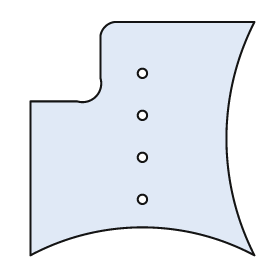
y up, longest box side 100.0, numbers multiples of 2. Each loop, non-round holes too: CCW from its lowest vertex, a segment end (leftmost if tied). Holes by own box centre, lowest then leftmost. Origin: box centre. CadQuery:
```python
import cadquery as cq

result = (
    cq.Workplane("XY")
    .moveTo(-48.0, -50.0)
    .threePointArc((0.0, -38.0), (48.0, -50.0))
    .threePointArc((36.0, 0.0), (48.0, 50.0))
    .lineTo(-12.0, 50.0)
    .threePointArc((-16.0, 48.0), (-18.0, 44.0))
    .lineTo(-18.0, 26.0)
    .threePointArc((-20.0, 18.0), (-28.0, 16.0))
    .lineTo(-48.0, 16.0)
    .close()
    .moveTo(0.0, -26.0)
    .circle(2.0)
    .moveTo(0.0, -8.0)
    .circle(2.0)
    .moveTo(0.0, 10.0)
    .circle(2.0)
    .moveTo(0.0, 28.0)
    .circle(2.0)
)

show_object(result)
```